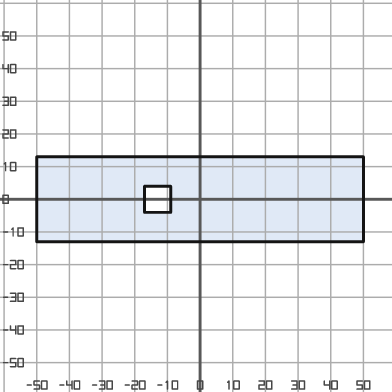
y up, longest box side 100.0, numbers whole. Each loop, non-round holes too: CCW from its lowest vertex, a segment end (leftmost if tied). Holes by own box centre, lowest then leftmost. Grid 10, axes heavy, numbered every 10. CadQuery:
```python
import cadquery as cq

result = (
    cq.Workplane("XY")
    .moveTo(-50.0, -13.0)
    .lineTo(50.0, -13.0)
    .lineTo(50.0, 13.0)
    .lineTo(-50.0, 13.0)
    .close()
    .moveTo(-17.0, -4.0)
    .lineTo(-9.0, -4.0)
    .lineTo(-9.0, 4.0)
    .lineTo(-17.0, 4.0)
    .close()
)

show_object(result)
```